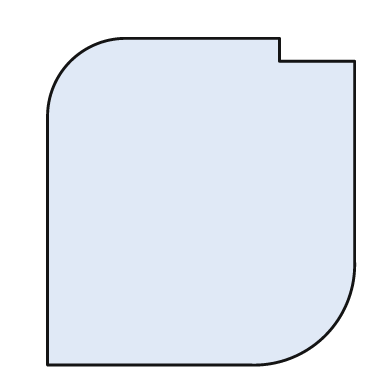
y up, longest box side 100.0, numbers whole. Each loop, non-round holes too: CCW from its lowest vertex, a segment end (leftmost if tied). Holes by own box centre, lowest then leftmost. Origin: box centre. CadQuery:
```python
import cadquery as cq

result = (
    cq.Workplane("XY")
    .moveTo(-47.0, -50.0)
    .lineTo(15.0, -50.0)
    .threePointArc((38.0, -41.0), (47.0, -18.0))
    .lineTo(47.0, 43.0)
    .lineTo(24.0, 43.0)
    .lineTo(24.0, 50.0)
    .lineTo(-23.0, 50.0)
    .threePointArc((-40.0, 43.0), (-47.0, 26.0))
    .close()
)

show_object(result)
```